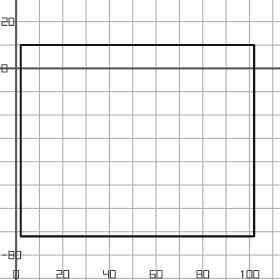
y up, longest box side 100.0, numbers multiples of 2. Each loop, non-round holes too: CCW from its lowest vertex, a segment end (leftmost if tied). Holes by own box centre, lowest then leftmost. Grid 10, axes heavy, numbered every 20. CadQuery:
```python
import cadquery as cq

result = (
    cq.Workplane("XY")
    .moveTo(2.0, -72.0)
    .lineTo(102.0, -72.0)
    .lineTo(102.0, 10.0)
    .lineTo(2.0, 10.0)
    .close()
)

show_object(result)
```